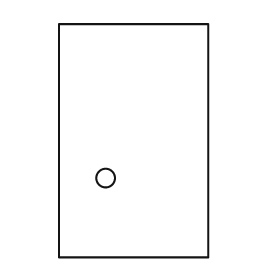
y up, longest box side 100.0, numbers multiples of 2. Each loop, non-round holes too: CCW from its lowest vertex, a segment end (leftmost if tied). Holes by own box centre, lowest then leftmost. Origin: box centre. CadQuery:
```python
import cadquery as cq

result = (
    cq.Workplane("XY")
    .moveTo(-32.0, -50.0)
    .lineTo(32.0, -50.0)
    .lineTo(32.0, 50.0)
    .lineTo(-32.0, 50.0)
    .close()
    .moveTo(-12.0, -16.0)
    .circle(4.0)
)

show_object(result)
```